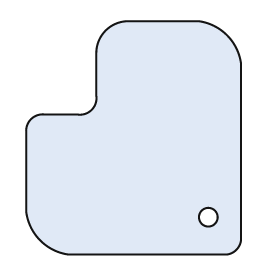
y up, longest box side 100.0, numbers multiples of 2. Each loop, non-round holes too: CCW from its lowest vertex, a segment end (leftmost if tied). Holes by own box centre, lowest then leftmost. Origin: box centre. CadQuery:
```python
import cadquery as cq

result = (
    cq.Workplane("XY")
    .moveTo(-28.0, -50.0)
    .lineTo(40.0, -50.0)
    .threePointArc((44.0, -48.0), (46.0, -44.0))
    .lineTo(46.0, 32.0)
    .threePointArc((40.0, 44.0), (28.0, 50.0))
    .lineTo(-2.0, 50.0)
    .threePointArc((-12.0, 46.0), (-16.0, 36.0))
    .lineTo(-16.0, 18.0)
    .threePointArc((-18.0, 12.0), (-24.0, 10.0))
    .lineTo(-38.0, 10.0)
    .threePointArc((-44.0, 8.0), (-46.0, 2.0))
    .lineTo(-46.0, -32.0)
    .threePointArc((-40.0, -44.0), (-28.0, -50.0))
    .close()
    .moveTo(32.0, -34.0)
    .circle(4.0)
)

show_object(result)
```